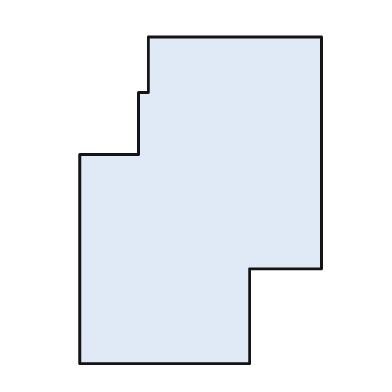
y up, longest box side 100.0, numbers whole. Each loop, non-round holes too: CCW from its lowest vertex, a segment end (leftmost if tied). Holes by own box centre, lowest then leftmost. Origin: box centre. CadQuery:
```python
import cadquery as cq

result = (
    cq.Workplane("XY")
    .moveTo(-37.0, -50.0)
    .lineTo(15.0, -50.0)
    .lineTo(15.0, -21.0)
    .lineTo(37.0, -21.0)
    .lineTo(37.0, 50.0)
    .lineTo(-16.0, 50.0)
    .lineTo(-16.0, 33.0)
    .lineTo(-19.0, 33.0)
    .lineTo(-19.0, 14.0)
    .lineTo(-37.0, 14.0)
    .close()
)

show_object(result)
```